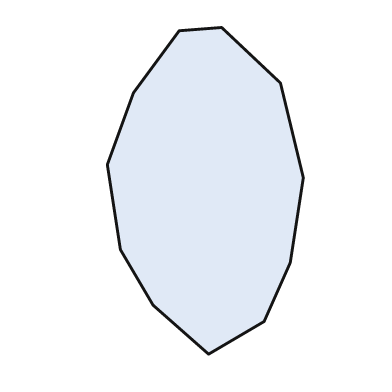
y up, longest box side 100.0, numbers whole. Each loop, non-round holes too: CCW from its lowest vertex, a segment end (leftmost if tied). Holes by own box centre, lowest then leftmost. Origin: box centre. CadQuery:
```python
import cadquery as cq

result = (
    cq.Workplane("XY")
    .moveTo(1.0, -50.0)
    .lineTo(18.0, -40.0)
    .lineTo(26.0, -22.0)
    .lineTo(30.0, 4.0)
    .lineTo(23.0, 33.0)
    .lineTo(5.0, 50.0)
    .lineTo(-8.0, 49.0)
    .lineTo(-22.0, 30.0)
    .lineTo(-30.0, 8.0)
    .lineTo(-26.0, -18.0)
    .lineTo(-16.0, -35.0)
    .close()
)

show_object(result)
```